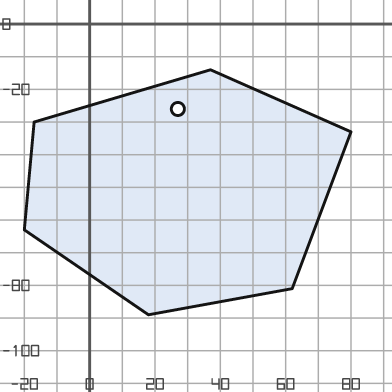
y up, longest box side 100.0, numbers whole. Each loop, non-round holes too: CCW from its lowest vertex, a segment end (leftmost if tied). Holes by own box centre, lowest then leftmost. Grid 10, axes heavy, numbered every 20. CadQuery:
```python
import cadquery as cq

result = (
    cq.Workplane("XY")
    .moveTo(18.0, -89.0)
    .lineTo(62.0, -81.0)
    .lineTo(80.0, -33.0)
    .lineTo(37.0, -14.0)
    .lineTo(-17.0, -30.0)
    .lineTo(-20.0, -63.0)
    .close()
    .moveTo(27.0, -26.0)
    .circle(2.0)
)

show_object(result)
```